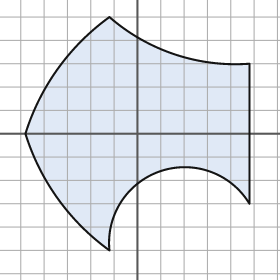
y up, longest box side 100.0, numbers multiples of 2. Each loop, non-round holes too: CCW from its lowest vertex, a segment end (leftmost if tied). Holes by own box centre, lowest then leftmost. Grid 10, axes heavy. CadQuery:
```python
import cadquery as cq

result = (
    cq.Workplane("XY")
    .moveTo(-12.0, -50.0)
    .threePointArc((10.0, -16.0), (48.0, -30.0))
    .lineTo(48.0, 30.0)
    .threePointArc((16.0, 34.0), (-12.0, 50.0))
    .threePointArc((-34.0, 28.0), (-48.0, 0.0))
    .threePointArc((-34.0, -28.0), (-12.0, -50.0))
    .close()
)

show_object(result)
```